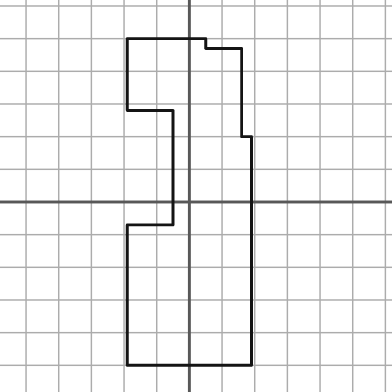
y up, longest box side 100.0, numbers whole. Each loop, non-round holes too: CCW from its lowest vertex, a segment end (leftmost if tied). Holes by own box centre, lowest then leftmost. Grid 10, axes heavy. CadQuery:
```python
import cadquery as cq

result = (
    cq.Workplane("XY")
    .moveTo(-19.0, -50.0)
    .lineTo(19.0, -50.0)
    .lineTo(19.0, 20.0)
    .lineTo(16.0, 20.0)
    .lineTo(16.0, 47.0)
    .lineTo(5.0, 47.0)
    .lineTo(5.0, 50.0)
    .lineTo(-19.0, 50.0)
    .lineTo(-19.0, 28.0)
    .lineTo(-5.0, 28.0)
    .lineTo(-5.0, -7.0)
    .lineTo(-19.0, -7.0)
    .close()
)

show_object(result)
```